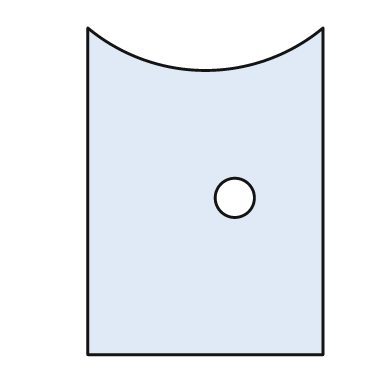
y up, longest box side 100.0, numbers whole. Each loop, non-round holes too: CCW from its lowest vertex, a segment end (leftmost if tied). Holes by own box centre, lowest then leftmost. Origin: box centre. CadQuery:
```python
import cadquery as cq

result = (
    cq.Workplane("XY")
    .moveTo(-36.0, -50.0)
    .lineTo(36.0, -50.0)
    .lineTo(36.0, 50.0)
    .threePointArc((0.0, 37.0), (-36.0, 50.0))
    .close()
    .moveTo(9.0, -2.0)
    .circle(6.0)
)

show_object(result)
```